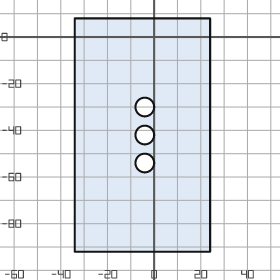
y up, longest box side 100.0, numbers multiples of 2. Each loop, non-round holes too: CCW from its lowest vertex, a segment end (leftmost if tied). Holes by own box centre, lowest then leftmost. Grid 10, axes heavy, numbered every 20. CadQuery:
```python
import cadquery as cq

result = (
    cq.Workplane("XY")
    .moveTo(-34.0, -92.0)
    .lineTo(24.0, -92.0)
    .lineTo(24.0, 8.0)
    .lineTo(-34.0, 8.0)
    .close()
    .moveTo(-4.0, -54.0)
    .circle(4.0)
    .moveTo(-4.0, -42.0)
    .circle(4.0)
    .moveTo(-4.0, -30.0)
    .circle(4.0)
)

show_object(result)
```